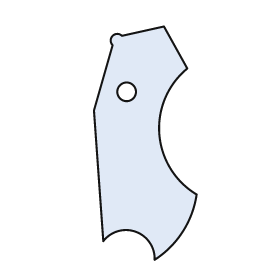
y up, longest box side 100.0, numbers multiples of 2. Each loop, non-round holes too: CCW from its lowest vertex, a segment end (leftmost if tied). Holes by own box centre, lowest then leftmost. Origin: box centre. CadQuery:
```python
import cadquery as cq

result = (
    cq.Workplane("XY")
    .moveTo(4.0, -50.0)
    .threePointArc((16.0, -38.0), (22.0, -22.0))
    .threePointArc((6.0, 4.0), (18.0, 32.0))
    .lineTo(8.0, 50.0)
    .lineTo(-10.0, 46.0)
    .threePointArc((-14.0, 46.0), (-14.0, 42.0))
    .lineTo(-22.0, 14.0)
    .lineTo(-18.0, -42.0)
    .threePointArc((-4.0, -38.0), (4.0, -50.0))
    .close()
    .moveTo(-8.0, 22.0)
    .circle(4.0)
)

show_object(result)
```